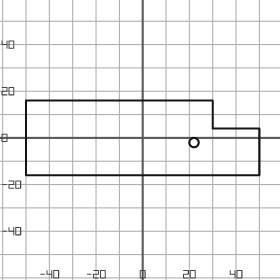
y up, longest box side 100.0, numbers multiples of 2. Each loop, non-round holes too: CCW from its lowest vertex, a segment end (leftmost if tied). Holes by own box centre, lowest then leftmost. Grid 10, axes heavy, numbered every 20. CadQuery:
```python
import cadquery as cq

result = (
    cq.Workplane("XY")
    .moveTo(-50.0, -16.0)
    .lineTo(50.0, -16.0)
    .lineTo(50.0, 4.0)
    .lineTo(30.0, 4.0)
    .lineTo(30.0, 16.0)
    .lineTo(-50.0, 16.0)
    .close()
    .moveTo(22.0, -2.0)
    .circle(2.0)
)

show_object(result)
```